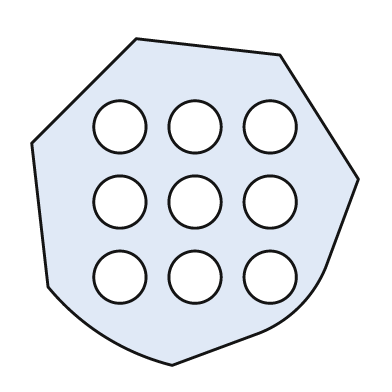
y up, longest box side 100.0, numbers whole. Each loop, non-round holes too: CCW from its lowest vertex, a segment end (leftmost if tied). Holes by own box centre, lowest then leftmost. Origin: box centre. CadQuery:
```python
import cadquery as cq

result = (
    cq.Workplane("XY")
    .moveTo(-7.0, -50.0)
    .lineTo(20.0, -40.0)
    .threePointArc((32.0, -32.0), (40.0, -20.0))
    .lineTo(50.0, 7.0)
    .lineTo(26.0, 45.0)
    .lineTo(-18.0, 50.0)
    .lineTo(-50.0, 18.0)
    .lineTo(-45.0, -26.0)
    .threePointArc((-28.0, -41.0), (-7.0, -50.0))
    .close()
    .moveTo(-23.0, -23.0)
    .circle(8.0)
    .moveTo(0.0, -23.0)
    .circle(8.0)
    .moveTo(23.0, -23.0)
    .circle(8.0)
    .moveTo(-23.0, 0.0)
    .circle(8.0)
    .moveTo(0.0, 0.0)
    .circle(8.0)
    .moveTo(23.0, 0.0)
    .circle(8.0)
    .moveTo(-23.0, 23.0)
    .circle(8.0)
    .moveTo(0.0, 23.0)
    .circle(8.0)
    .moveTo(23.0, 23.0)
    .circle(8.0)
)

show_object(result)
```